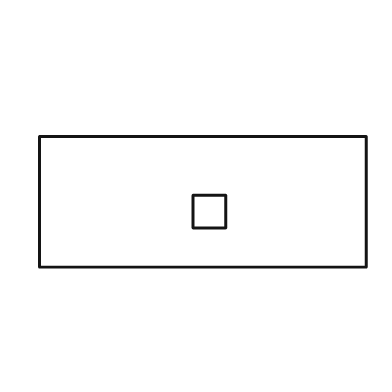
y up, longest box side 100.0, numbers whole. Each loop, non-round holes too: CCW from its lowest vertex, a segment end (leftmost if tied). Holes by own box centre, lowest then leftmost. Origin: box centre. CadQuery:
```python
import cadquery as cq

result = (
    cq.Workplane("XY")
    .moveTo(-50.0, -20.0)
    .lineTo(50.0, -20.0)
    .lineTo(50.0, 20.0)
    .lineTo(-50.0, 20.0)
    .close()
    .moveTo(-3.0, -8.0)
    .lineTo(7.0, -8.0)
    .lineTo(7.0, 2.0)
    .lineTo(-3.0, 2.0)
    .close()
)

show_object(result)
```